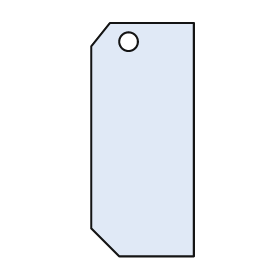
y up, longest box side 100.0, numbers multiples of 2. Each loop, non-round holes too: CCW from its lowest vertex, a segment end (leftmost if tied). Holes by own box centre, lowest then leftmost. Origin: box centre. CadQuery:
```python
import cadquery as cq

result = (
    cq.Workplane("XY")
    .moveTo(-10.0, -50.0)
    .lineTo(22.0, -50.0)
    .lineTo(22.0, 50.0)
    .lineTo(-14.0, 50.0)
    .lineTo(-22.0, 40.0)
    .lineTo(-22.0, -38.0)
    .close()
    .moveTo(-6.0, 42.0)
    .circle(4.0)
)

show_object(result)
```